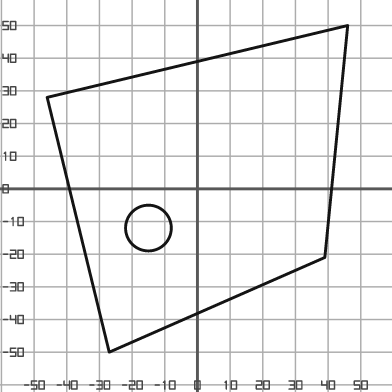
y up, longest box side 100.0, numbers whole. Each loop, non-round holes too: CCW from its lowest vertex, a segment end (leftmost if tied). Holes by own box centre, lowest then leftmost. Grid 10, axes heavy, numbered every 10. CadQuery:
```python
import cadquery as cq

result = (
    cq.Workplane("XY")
    .moveTo(-27.0, -50.0)
    .lineTo(39.0, -21.0)
    .lineTo(46.0, 50.0)
    .lineTo(-46.0, 28.0)
    .close()
    .moveTo(-15.0, -12.0)
    .circle(7.0)
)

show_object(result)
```